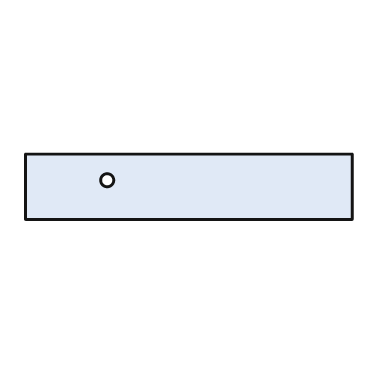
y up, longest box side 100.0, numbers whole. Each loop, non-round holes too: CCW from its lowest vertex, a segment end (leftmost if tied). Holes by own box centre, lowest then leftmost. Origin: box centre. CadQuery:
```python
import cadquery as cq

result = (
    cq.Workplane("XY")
    .moveTo(-50.0, -10.0)
    .lineTo(50.0, -10.0)
    .lineTo(50.0, 10.0)
    .lineTo(-50.0, 10.0)
    .close()
    .moveTo(-25.0, 2.0)
    .circle(2.0)
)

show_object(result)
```